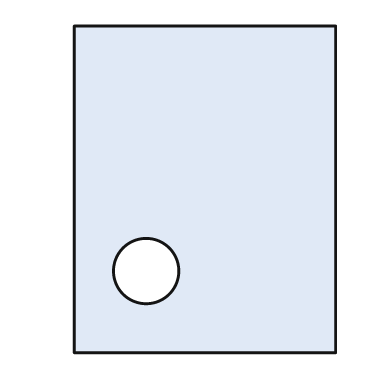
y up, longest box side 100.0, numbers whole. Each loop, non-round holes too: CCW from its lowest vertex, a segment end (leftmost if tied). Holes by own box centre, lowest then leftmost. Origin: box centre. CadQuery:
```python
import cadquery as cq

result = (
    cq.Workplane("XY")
    .moveTo(-40.0, -50.0)
    .lineTo(40.0, -50.0)
    .lineTo(40.0, 50.0)
    .lineTo(-40.0, 50.0)
    .close()
    .moveTo(-18.0, -25.0)
    .circle(10.0)
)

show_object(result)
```